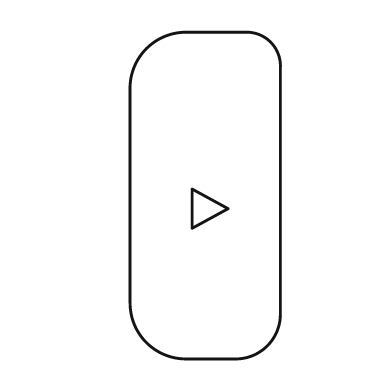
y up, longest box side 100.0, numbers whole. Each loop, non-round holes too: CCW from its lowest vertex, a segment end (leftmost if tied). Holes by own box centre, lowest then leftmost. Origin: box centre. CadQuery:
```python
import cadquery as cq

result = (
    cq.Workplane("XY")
    .moveTo(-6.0, -50.0)
    .lineTo(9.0, -50.0)
    .threePointArc((19.0, -46.0), (23.0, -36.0))
    .lineTo(23.0, 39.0)
    .threePointArc((20.0, 47.0), (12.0, 50.0))
    .lineTo(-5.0, 50.0)
    .threePointArc((-18.0, 45.0), (-23.0, 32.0))
    .lineTo(-23.0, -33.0)
    .threePointArc((-18.0, -45.0), (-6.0, -50.0))
    .close()
    .moveTo(-4.0, -10.0)
    .lineTo(7.0, -4.0)
    .lineTo(-4.0, 2.0)
    .close()
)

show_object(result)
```